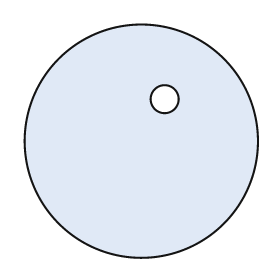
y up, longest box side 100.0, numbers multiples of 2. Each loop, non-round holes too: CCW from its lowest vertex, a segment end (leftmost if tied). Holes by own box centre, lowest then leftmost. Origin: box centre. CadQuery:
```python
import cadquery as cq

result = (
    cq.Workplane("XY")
    .moveTo(0.0, 0.0)
    .circle(50.0)
    .moveTo(10.0, 18.0)
    .circle(6.0)
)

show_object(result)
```